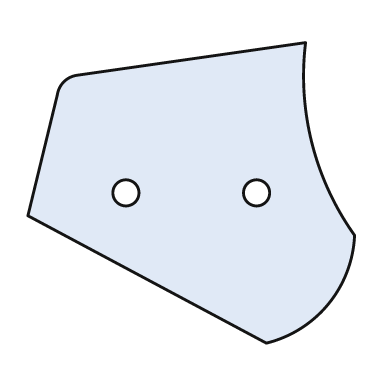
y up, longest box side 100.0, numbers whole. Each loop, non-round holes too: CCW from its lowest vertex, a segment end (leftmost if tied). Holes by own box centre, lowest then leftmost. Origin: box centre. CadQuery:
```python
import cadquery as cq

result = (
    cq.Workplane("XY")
    .moveTo(23.0, -46.0)
    .threePointArc((42.0, -34.0), (50.0, -13.0))
    .threePointArc((37.0, 15.0), (35.0, 46.0))
    .lineTo(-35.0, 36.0)
    .threePointArc((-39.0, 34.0), (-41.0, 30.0))
    .lineTo(-50.0, -7.0)
    .close()
    .moveTo(-20.0, 0.0)
    .circle(4.0)
    .moveTo(20.0, 0.0)
    .circle(4.0)
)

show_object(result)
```